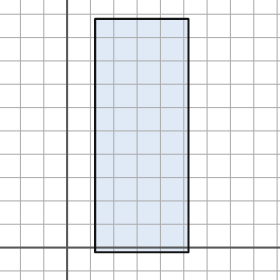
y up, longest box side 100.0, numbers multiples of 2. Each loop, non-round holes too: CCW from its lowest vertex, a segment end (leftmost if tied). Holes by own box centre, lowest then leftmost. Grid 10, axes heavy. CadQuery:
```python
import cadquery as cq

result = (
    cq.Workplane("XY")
    .moveTo(12.0, -2.0)
    .lineTo(52.0, -2.0)
    .lineTo(52.0, 98.0)
    .lineTo(12.0, 98.0)
    .close()
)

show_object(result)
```